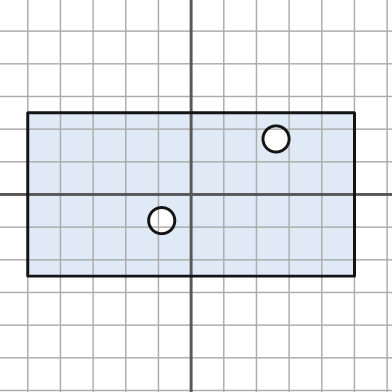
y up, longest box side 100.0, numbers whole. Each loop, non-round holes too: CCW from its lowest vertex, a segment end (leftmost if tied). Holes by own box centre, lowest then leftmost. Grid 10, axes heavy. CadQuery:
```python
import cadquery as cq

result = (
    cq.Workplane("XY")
    .moveTo(-50.0, -25.0)
    .lineTo(50.0, -25.0)
    .lineTo(50.0, 25.0)
    .lineTo(-50.0, 25.0)
    .close()
    .moveTo(-9.0, -8.0)
    .circle(4.0)
    .moveTo(26.0, 17.0)
    .circle(4.0)
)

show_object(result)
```